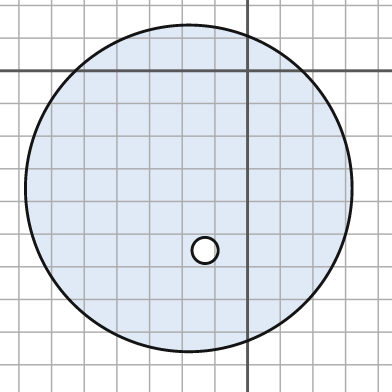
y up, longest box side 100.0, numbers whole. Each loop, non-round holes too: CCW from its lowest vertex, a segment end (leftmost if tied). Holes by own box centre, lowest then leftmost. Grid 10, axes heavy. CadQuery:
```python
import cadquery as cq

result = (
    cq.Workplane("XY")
    .moveTo(-18.0, -36.0)
    .circle(50.0)
    .moveTo(-13.0, -55.0)
    .circle(4.0)
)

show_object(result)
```